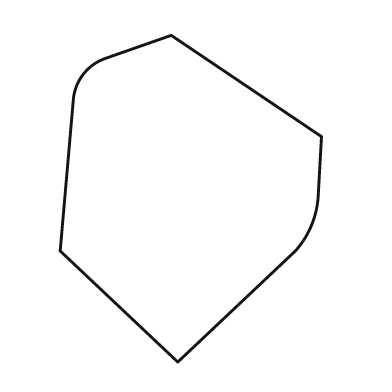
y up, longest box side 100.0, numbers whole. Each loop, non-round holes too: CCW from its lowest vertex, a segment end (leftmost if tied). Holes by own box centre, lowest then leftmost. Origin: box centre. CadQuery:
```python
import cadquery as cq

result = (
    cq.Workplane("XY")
    .moveTo(-4.0, -50.0)
    .lineTo(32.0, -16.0)
    .threePointArc((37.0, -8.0), (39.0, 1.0))
    .lineTo(40.0, 19.0)
    .lineTo(-6.0, 50.0)
    .lineTo(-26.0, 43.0)
    .threePointArc((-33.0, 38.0), (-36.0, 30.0))
    .lineTo(-40.0, -16.0)
    .close()
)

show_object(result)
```